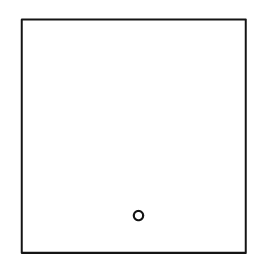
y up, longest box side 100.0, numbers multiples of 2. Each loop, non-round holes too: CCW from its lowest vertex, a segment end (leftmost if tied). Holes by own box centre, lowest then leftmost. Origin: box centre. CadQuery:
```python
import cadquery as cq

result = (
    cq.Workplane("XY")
    .moveTo(-48.0, -50.0)
    .lineTo(48.0, -50.0)
    .lineTo(48.0, 50.0)
    .lineTo(-48.0, 50.0)
    .close()
    .moveTo(2.0, -34.0)
    .circle(2.0)
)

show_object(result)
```